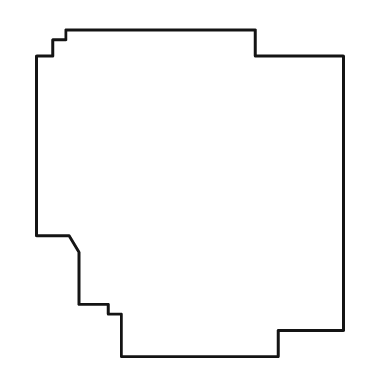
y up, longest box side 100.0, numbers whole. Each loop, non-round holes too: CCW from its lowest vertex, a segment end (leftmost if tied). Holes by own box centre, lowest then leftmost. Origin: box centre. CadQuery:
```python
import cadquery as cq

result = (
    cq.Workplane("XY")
    .moveTo(-21.0, -50.0)
    .lineTo(27.0, -50.0)
    .lineTo(27.0, -42.0)
    .lineTo(47.0, -42.0)
    .lineTo(47.0, 42.0)
    .lineTo(20.0, 42.0)
    .lineTo(20.0, 50.0)
    .lineTo(-38.0, 50.0)
    .lineTo(-38.0, 47.0)
    .lineTo(-42.0, 47.0)
    .lineTo(-42.0, 42.0)
    .lineTo(-47.0, 42.0)
    .lineTo(-47.0, -13.0)
    .lineTo(-37.0, -13.0)
    .lineTo(-34.0, -18.0)
    .lineTo(-34.0, -34.0)
    .lineTo(-25.0, -34.0)
    .lineTo(-25.0, -37.0)
    .lineTo(-21.0, -37.0)
    .close()
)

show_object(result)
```